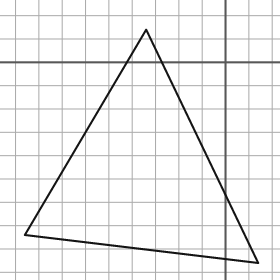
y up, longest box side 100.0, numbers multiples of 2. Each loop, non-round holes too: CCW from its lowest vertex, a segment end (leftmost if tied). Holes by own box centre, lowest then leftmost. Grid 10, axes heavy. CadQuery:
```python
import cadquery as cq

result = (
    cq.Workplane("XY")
    .moveTo(14.0, -86.0)
    .lineTo(-34.0, 14.0)
    .lineTo(-86.0, -74.0)
    .close()
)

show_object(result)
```